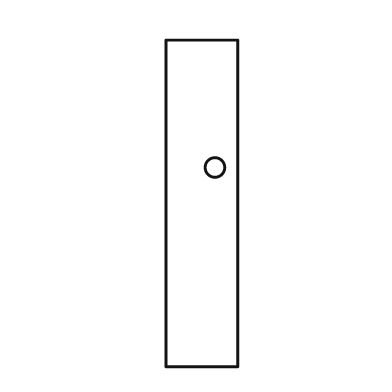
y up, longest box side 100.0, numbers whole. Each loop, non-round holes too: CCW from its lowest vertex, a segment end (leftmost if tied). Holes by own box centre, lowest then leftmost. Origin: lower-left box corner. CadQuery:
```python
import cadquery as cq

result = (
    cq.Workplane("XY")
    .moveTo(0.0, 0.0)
    .lineTo(22.0, 0.0)
    .lineTo(22.0, 100.0)
    .lineTo(0.0, 100.0)
    .close()
    .moveTo(15.0, 61.0)
    .circle(3.0)
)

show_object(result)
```